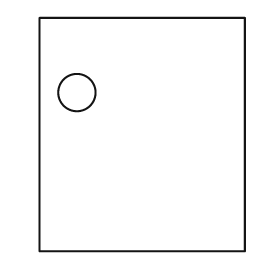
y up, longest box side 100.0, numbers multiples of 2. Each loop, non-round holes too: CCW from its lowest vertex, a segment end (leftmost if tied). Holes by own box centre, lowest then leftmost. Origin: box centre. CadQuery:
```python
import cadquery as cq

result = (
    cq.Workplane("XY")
    .moveTo(-44.0, -50.0)
    .lineTo(44.0, -50.0)
    .lineTo(44.0, 50.0)
    .lineTo(-44.0, 50.0)
    .close()
    .moveTo(-28.0, 18.0)
    .circle(8.0)
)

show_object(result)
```